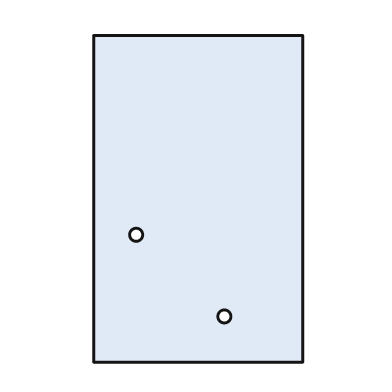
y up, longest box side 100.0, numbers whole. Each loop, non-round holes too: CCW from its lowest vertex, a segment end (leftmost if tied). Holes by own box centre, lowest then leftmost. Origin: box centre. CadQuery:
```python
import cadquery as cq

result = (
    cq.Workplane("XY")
    .moveTo(-32.0, -50.0)
    .lineTo(32.0, -50.0)
    .lineTo(32.0, 50.0)
    .lineTo(-32.0, 50.0)
    .close()
    .moveTo(8.0, -36.0)
    .circle(2.0)
    .moveTo(-19.0, -11.0)
    .circle(2.0)
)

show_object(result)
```